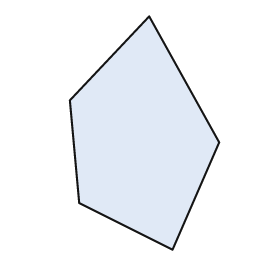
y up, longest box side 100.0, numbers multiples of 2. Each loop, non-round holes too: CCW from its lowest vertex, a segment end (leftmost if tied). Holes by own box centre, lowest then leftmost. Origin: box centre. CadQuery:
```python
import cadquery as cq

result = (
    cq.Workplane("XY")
    .moveTo(12.0, -50.0)
    .lineTo(32.0, -4.0)
    .lineTo(2.0, 50.0)
    .lineTo(-32.0, 14.0)
    .lineTo(-28.0, -30.0)
    .close()
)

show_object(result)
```